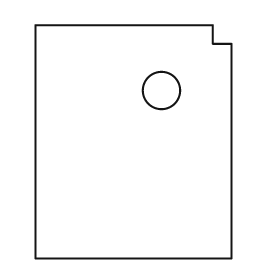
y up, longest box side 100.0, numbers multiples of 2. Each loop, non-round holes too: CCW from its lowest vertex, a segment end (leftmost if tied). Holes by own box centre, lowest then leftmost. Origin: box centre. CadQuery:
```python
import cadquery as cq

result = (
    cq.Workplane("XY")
    .moveTo(-42.0, -50.0)
    .lineTo(42.0, -50.0)
    .lineTo(42.0, 42.0)
    .lineTo(34.0, 42.0)
    .lineTo(34.0, 50.0)
    .lineTo(-42.0, 50.0)
    .close()
    .moveTo(12.0, 22.0)
    .circle(8.0)
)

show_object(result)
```